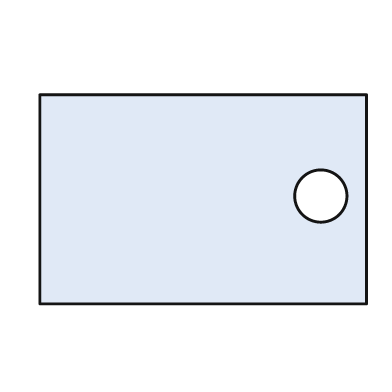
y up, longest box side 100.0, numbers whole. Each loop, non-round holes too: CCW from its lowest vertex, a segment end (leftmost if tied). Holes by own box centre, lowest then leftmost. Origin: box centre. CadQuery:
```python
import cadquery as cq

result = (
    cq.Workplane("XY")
    .moveTo(-50.0, -32.0)
    .lineTo(50.0, -32.0)
    .lineTo(50.0, 32.0)
    .lineTo(-50.0, 32.0)
    .close()
    .moveTo(36.0, 1.0)
    .circle(8.0)
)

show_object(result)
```